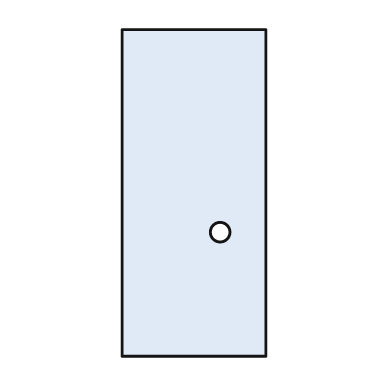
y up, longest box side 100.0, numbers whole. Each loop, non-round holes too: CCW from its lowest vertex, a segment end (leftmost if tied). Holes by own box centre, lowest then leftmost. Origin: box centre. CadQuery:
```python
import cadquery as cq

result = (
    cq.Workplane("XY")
    .moveTo(-22.0, -50.0)
    .lineTo(22.0, -50.0)
    .lineTo(22.0, 50.0)
    .lineTo(-22.0, 50.0)
    .close()
    .moveTo(8.0, -12.0)
    .circle(3.0)
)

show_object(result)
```